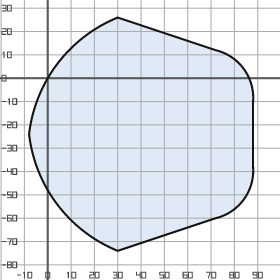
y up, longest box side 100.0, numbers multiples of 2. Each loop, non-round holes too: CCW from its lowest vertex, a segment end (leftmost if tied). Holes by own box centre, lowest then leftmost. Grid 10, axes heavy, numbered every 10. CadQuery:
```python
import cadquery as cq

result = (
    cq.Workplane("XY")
    .moveTo(30.0, -74.0)
    .lineTo(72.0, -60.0)
    .threePointArc((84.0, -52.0), (88.0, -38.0))
    .lineTo(88.0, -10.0)
    .threePointArc((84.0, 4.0), (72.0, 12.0))
    .lineTo(30.0, 26.0)
    .threePointArc((4.0, 6.0), (-8.0, -24.0))
    .threePointArc((4.0, -54.0), (30.0, -74.0))
    .close()
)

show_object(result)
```